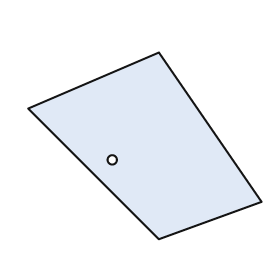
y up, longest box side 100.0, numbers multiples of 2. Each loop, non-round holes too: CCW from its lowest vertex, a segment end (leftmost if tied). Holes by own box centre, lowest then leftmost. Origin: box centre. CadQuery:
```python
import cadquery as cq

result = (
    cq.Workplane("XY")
    .moveTo(6.0, -40.0)
    .lineTo(50.0, -24.0)
    .lineTo(6.0, 40.0)
    .lineTo(-50.0, 16.0)
    .close()
    .moveTo(-14.0, -6.0)
    .circle(2.0)
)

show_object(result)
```